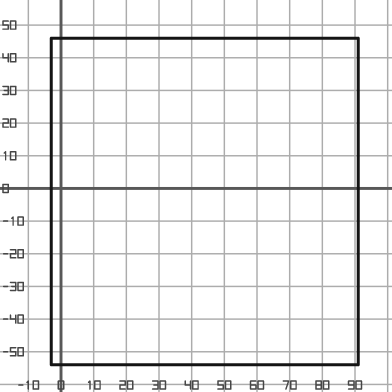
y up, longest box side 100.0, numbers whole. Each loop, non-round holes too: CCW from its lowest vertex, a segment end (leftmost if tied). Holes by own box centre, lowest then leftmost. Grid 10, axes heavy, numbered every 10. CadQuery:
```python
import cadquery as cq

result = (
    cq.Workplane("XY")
    .moveTo(-3.0, -54.0)
    .lineTo(91.0, -54.0)
    .lineTo(91.0, 46.0)
    .lineTo(-3.0, 46.0)
    .close()
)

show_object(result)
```